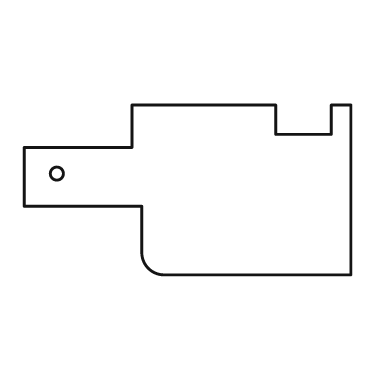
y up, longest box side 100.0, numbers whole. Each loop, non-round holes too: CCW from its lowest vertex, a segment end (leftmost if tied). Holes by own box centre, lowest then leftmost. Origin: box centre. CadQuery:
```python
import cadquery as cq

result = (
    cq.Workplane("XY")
    .moveTo(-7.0, -26.0)
    .lineTo(50.0, -26.0)
    .lineTo(50.0, 26.0)
    .lineTo(44.0, 26.0)
    .lineTo(44.0, 17.0)
    .lineTo(27.0, 17.0)
    .lineTo(27.0, 26.0)
    .lineTo(-17.0, 26.0)
    .lineTo(-17.0, 13.0)
    .lineTo(-50.0, 13.0)
    .lineTo(-50.0, -5.0)
    .lineTo(-14.0, -5.0)
    .lineTo(-14.0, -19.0)
    .threePointArc((-12.0, -24.0), (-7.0, -26.0))
    .close()
    .moveTo(-40.0, 5.0)
    .circle(2.0)
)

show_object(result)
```